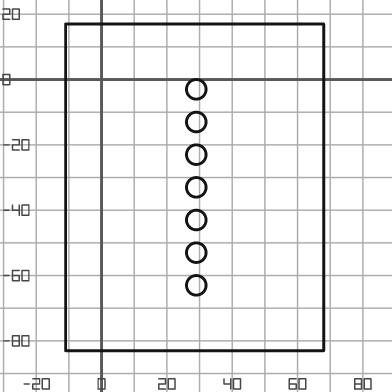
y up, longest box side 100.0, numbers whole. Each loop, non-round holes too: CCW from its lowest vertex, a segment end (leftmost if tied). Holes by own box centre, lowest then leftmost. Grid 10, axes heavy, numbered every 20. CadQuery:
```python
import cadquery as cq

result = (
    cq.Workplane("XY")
    .moveTo(-11.0, -83.0)
    .lineTo(68.0, -83.0)
    .lineTo(68.0, 17.0)
    .lineTo(-11.0, 17.0)
    .close()
    .moveTo(29.0, -63.0)
    .circle(3.0)
    .moveTo(29.0, -53.0)
    .circle(3.0)
    .moveTo(29.0, -43.0)
    .circle(3.0)
    .moveTo(29.0, -33.0)
    .circle(3.0)
    .moveTo(29.0, -23.0)
    .circle(3.0)
    .moveTo(29.0, -13.0)
    .circle(3.0)
    .moveTo(29.0, -3.0)
    .circle(3.0)
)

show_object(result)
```